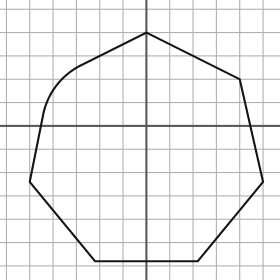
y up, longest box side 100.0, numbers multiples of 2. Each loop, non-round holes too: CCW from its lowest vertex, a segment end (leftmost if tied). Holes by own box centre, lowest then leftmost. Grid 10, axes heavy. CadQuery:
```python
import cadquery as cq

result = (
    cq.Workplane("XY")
    .moveTo(-22.0, -58.0)
    .lineTo(22.0, -58.0)
    .lineTo(50.0, -24.0)
    .lineTo(40.0, 20.0)
    .lineTo(0.0, 40.0)
    .lineTo(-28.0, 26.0)
    .threePointArc((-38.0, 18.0), (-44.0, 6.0))
    .lineTo(-50.0, -24.0)
    .close()
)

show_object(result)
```